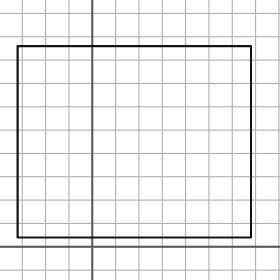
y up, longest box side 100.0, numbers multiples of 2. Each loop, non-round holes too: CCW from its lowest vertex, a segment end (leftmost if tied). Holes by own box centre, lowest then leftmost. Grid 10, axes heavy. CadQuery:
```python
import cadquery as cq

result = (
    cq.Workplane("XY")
    .moveTo(-32.0, 4.0)
    .lineTo(68.0, 4.0)
    .lineTo(68.0, 86.0)
    .lineTo(-32.0, 86.0)
    .close()
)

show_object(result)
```